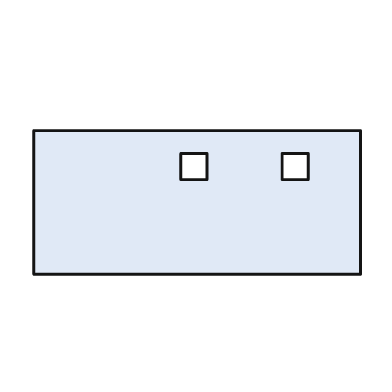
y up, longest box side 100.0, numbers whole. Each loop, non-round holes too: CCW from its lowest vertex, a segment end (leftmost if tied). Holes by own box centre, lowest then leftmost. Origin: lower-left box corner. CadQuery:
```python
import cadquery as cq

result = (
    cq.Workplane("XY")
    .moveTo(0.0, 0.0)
    .lineTo(100.0, 0.0)
    .lineTo(100.0, 44.0)
    .lineTo(0.0, 44.0)
    .close()
    .moveTo(45.0, 29.0)
    .lineTo(53.0, 29.0)
    .lineTo(53.0, 37.0)
    .lineTo(45.0, 37.0)
    .close()
    .moveTo(76.0, 29.0)
    .lineTo(84.0, 29.0)
    .lineTo(84.0, 37.0)
    .lineTo(76.0, 37.0)
    .close()
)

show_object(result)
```